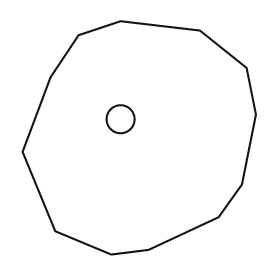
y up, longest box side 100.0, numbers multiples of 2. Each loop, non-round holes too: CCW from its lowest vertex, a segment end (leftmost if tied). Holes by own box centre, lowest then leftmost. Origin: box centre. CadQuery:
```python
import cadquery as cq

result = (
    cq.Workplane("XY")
    .moveTo(-12.0, -50.0)
    .lineTo(4.0, -48.0)
    .lineTo(34.0, -34.0)
    .lineTo(44.0, -20.0)
    .lineTo(50.0, 10.0)
    .lineTo(46.0, 30.0)
    .lineTo(26.0, 46.0)
    .lineTo(-8.0, 50.0)
    .lineTo(-26.0, 44.0)
    .lineTo(-38.0, 26.0)
    .lineTo(-50.0, -6.0)
    .lineTo(-36.0, -40.0)
    .close()
    .moveTo(-8.0, 8.0)
    .circle(6.0)
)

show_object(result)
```